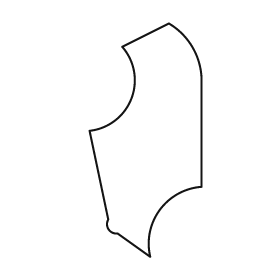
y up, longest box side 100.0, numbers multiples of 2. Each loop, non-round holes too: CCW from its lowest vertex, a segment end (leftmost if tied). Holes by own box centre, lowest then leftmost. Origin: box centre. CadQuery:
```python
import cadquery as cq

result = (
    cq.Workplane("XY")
    .moveTo(2.0, -50.0)
    .threePointArc((6.0, -30.0), (24.0, -20.0))
    .lineTo(24.0, 26.0)
    .threePointArc((20.0, 40.0), (10.0, 50.0))
    .lineTo(-10.0, 40.0)
    .threePointArc((-6.0, 18.0), (-24.0, 4.0))
    .lineTo(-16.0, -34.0)
    .threePointArc((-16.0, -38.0), (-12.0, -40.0))
    .close()
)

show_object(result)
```